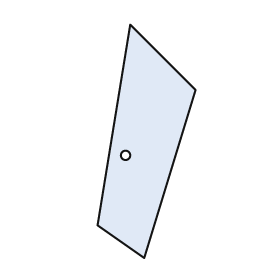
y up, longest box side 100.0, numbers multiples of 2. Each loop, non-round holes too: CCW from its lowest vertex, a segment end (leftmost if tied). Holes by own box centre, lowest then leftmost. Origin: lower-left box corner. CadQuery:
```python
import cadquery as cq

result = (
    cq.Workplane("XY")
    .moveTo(20.0, 0.0)
    .lineTo(42.0, 72.0)
    .lineTo(14.0, 100.0)
    .lineTo(0.0, 14.0)
    .close()
    .moveTo(12.0, 44.0)
    .circle(2.0)
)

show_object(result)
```